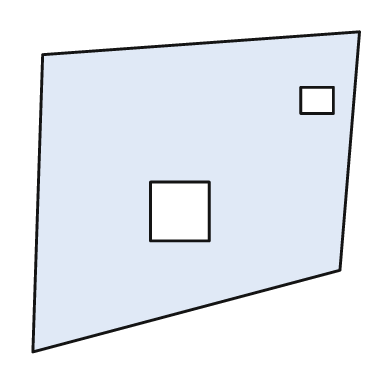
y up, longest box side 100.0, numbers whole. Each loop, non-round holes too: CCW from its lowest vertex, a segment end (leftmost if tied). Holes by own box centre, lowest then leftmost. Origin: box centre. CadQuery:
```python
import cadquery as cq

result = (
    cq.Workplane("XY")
    .moveTo(-50.0, -49.0)
    .lineTo(44.0, -24.0)
    .lineTo(50.0, 49.0)
    .lineTo(-47.0, 42.0)
    .close()
    .moveTo(-14.0, -15.0)
    .lineTo(4.0, -15.0)
    .lineTo(4.0, 3.0)
    .lineTo(-14.0, 3.0)
    .close()
    .moveTo(32.0, 24.0)
    .lineTo(42.0, 24.0)
    .lineTo(42.0, 32.0)
    .lineTo(32.0, 32.0)
    .close()
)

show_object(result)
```